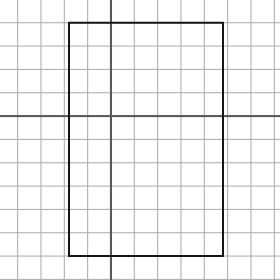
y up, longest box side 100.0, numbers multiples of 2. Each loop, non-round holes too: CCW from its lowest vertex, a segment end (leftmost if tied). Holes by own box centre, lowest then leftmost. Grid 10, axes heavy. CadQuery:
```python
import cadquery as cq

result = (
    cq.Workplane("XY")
    .moveTo(-18.0, -60.0)
    .lineTo(48.0, -60.0)
    .lineTo(48.0, 40.0)
    .lineTo(-18.0, 40.0)
    .close()
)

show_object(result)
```